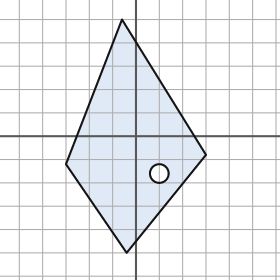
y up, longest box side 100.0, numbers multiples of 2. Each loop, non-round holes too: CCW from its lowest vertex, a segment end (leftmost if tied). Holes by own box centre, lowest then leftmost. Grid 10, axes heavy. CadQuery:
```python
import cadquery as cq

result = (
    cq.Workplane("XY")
    .moveTo(-4.0, -50.0)
    .lineTo(30.0, -8.0)
    .lineTo(-6.0, 50.0)
    .lineTo(-30.0, -12.0)
    .close()
    .moveTo(10.0, -16.0)
    .circle(4.0)
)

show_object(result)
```